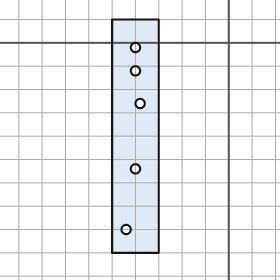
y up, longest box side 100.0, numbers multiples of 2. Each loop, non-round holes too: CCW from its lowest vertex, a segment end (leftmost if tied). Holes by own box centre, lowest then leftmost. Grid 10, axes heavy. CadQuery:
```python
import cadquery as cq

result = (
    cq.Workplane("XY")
    .moveTo(-50.0, -90.0)
    .lineTo(-30.0, -90.0)
    .lineTo(-30.0, 10.0)
    .lineTo(-50.0, 10.0)
    .close()
    .moveTo(-44.0, -80.0)
    .circle(2.0)
    .moveTo(-40.0, -54.0)
    .circle(2.0)
    .moveTo(-38.0, -26.0)
    .circle(2.0)
    .moveTo(-40.0, -12.0)
    .circle(2.0)
    .moveTo(-40.0, -2.0)
    .circle(2.0)
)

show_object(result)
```